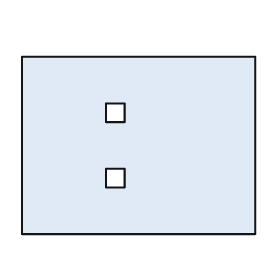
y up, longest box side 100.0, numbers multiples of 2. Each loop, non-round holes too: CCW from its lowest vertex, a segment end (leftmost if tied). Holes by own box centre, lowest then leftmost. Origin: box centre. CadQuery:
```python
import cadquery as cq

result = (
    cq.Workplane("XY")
    .moveTo(-50.0, -38.0)
    .lineTo(50.0, -38.0)
    .lineTo(50.0, 38.0)
    .lineTo(-50.0, 38.0)
    .close()
    .moveTo(-14.0, -18.0)
    .lineTo(-6.0, -18.0)
    .lineTo(-6.0, -10.0)
    .lineTo(-14.0, -10.0)
    .close()
    .moveTo(-14.0, 10.0)
    .lineTo(-6.0, 10.0)
    .lineTo(-6.0, 18.0)
    .lineTo(-14.0, 18.0)
    .close()
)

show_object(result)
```